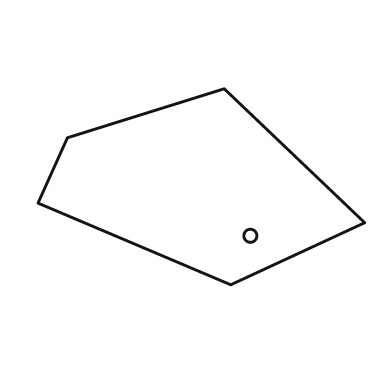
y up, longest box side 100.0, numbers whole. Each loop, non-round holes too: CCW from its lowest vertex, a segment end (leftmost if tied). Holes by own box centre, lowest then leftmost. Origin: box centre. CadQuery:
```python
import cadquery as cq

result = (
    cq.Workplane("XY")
    .moveTo(9.0, -30.0)
    .lineTo(50.0, -11.0)
    .lineTo(7.0, 30.0)
    .lineTo(-41.0, 15.0)
    .lineTo(-50.0, -5.0)
    .close()
    .moveTo(15.0, -15.0)
    .circle(2.0)
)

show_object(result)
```